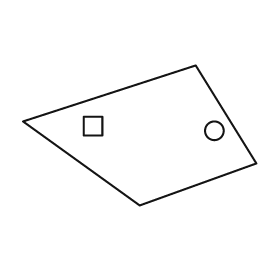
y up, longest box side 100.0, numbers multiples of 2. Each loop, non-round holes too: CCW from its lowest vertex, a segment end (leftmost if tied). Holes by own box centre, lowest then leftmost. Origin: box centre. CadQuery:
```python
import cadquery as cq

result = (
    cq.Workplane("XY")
    .moveTo(0.0, -30.0)
    .lineTo(50.0, -12.0)
    .lineTo(24.0, 30.0)
    .lineTo(-50.0, 6.0)
    .close()
    .moveTo(32.0, 2.0)
    .circle(4.0)
    .moveTo(-24.0, 0.0)
    .lineTo(-16.0, 0.0)
    .lineTo(-16.0, 8.0)
    .lineTo(-24.0, 8.0)
    .close()
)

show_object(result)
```